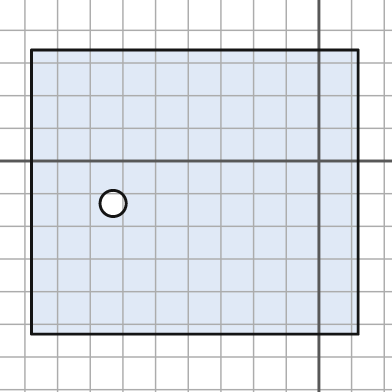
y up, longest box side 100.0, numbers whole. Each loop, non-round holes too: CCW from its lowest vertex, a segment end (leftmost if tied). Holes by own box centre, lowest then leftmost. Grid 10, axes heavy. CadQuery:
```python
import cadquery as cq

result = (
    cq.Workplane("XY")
    .moveTo(-88.0, -53.0)
    .lineTo(12.0, -53.0)
    .lineTo(12.0, 34.0)
    .lineTo(-88.0, 34.0)
    .close()
    .moveTo(-63.0, -13.0)
    .circle(4.0)
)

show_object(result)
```